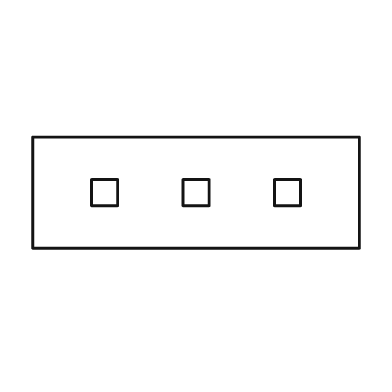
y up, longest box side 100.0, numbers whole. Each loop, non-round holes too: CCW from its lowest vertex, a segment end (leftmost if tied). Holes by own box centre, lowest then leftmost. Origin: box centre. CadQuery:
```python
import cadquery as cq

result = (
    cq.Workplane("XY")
    .moveTo(-50.0, -17.0)
    .lineTo(50.0, -17.0)
    .lineTo(50.0, 17.0)
    .lineTo(-50.0, 17.0)
    .close()
    .moveTo(-32.0, -4.0)
    .lineTo(-24.0, -4.0)
    .lineTo(-24.0, 4.0)
    .lineTo(-32.0, 4.0)
    .close()
    .moveTo(-4.0, -4.0)
    .lineTo(4.0, -4.0)
    .lineTo(4.0, 4.0)
    .lineTo(-4.0, 4.0)
    .close()
    .moveTo(24.0, -4.0)
    .lineTo(32.0, -4.0)
    .lineTo(32.0, 4.0)
    .lineTo(24.0, 4.0)
    .close()
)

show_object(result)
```